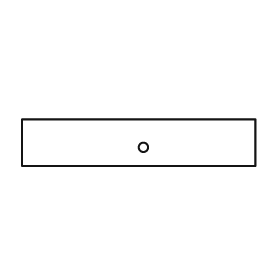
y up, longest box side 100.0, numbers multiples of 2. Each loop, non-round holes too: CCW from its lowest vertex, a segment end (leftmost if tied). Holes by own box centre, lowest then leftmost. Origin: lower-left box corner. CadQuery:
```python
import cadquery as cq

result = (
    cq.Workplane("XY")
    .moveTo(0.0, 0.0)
    .lineTo(100.0, 0.0)
    .lineTo(100.0, 20.0)
    .lineTo(0.0, 20.0)
    .close()
    .moveTo(52.0, 8.0)
    .circle(2.0)
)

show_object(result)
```